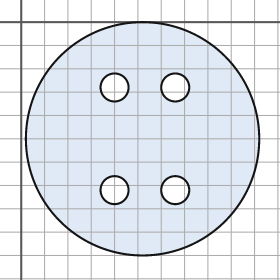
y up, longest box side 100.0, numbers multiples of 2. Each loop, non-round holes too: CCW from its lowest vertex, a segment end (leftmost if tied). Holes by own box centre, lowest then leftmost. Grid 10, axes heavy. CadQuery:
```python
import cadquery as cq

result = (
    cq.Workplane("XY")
    .moveTo(52.0, -50.0)
    .circle(50.0)
    .moveTo(40.0, -72.0)
    .circle(6.0)
    .moveTo(66.0, -72.0)
    .circle(6.0)
    .moveTo(40.0, -28.0)
    .circle(6.0)
    .moveTo(66.0, -28.0)
    .circle(6.0)
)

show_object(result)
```